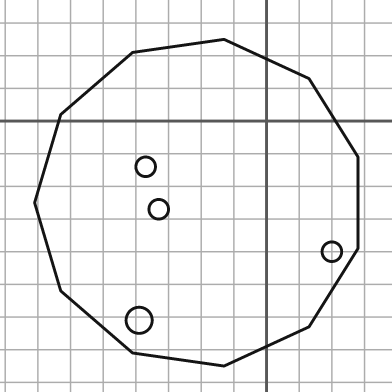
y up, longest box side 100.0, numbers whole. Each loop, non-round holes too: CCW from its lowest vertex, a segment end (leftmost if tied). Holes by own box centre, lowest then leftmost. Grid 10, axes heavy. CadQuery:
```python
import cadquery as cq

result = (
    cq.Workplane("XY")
    .moveTo(-13.0, -75.0)
    .lineTo(13.0, -63.0)
    .lineTo(28.0, -39.0)
    .lineTo(28.0, -11.0)
    .lineTo(13.0, 13.0)
    .lineTo(-13.0, 25.0)
    .lineTo(-41.0, 21.0)
    .lineTo(-63.0, 2.0)
    .lineTo(-71.0, -25.0)
    .lineTo(-63.0, -52.0)
    .lineTo(-41.0, -71.0)
    .close()
    .moveTo(-39.0, -61.0)
    .circle(4.0)
    .moveTo(20.0, -40.0)
    .circle(3.0)
    .moveTo(-33.0, -27.0)
    .circle(3.0)
    .moveTo(-37.0, -14.0)
    .circle(3.0)
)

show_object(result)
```